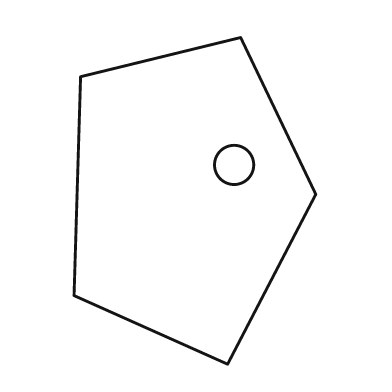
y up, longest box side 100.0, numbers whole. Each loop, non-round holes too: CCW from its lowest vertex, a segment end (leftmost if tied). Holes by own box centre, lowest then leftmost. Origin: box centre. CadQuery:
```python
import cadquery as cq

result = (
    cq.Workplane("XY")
    .moveTo(10.0, -50.0)
    .lineTo(37.0, 2.0)
    .lineTo(14.0, 50.0)
    .lineTo(-35.0, 38.0)
    .lineTo(-37.0, -29.0)
    .close()
    .moveTo(12.0, 11.0)
    .circle(6.0)
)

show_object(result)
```